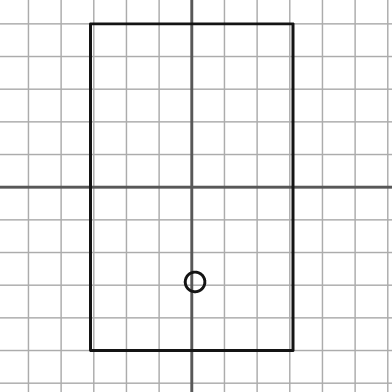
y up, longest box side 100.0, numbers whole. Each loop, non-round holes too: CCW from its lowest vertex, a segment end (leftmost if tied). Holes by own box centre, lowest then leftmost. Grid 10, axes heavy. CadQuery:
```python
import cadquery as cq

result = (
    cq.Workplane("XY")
    .moveTo(-31.0, -50.0)
    .lineTo(31.0, -50.0)
    .lineTo(31.0, 50.0)
    .lineTo(-31.0, 50.0)
    .close()
    .moveTo(1.0, -29.0)
    .circle(3.0)
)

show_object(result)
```